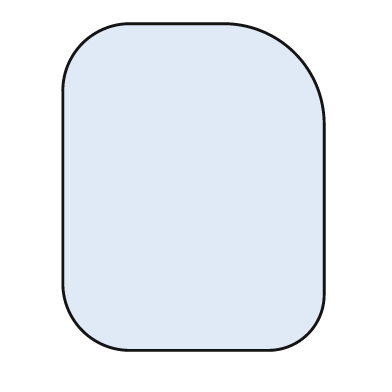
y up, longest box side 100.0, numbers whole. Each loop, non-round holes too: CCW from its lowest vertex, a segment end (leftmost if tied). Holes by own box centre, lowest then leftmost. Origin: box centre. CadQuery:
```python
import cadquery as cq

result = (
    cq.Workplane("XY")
    .moveTo(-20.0, -50.0)
    .lineTo(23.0, -50.0)
    .threePointArc((35.0, -45.0), (40.0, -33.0))
    .lineTo(40.0, 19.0)
    .threePointArc((31.0, 41.0), (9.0, 50.0))
    .lineTo(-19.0, 50.0)
    .threePointArc((-34.0, 44.0), (-40.0, 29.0))
    .lineTo(-40.0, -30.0)
    .threePointArc((-34.0, -44.0), (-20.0, -50.0))
    .close()
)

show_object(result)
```